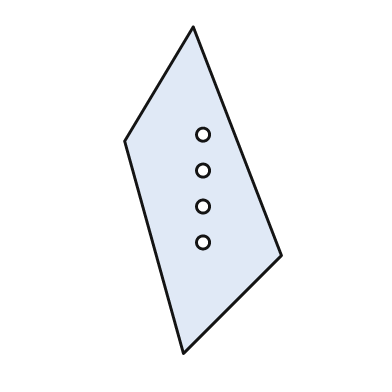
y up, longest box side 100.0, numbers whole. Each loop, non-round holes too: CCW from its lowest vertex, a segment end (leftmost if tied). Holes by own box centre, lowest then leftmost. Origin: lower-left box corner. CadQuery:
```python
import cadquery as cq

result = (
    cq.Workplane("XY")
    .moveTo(18.0, 0.0)
    .lineTo(48.0, 30.0)
    .lineTo(21.0, 100.0)
    .lineTo(0.0, 65.0)
    .close()
    .moveTo(24.0, 34.0)
    .circle(2.0)
    .moveTo(24.0, 45.0)
    .circle(2.0)
    .moveTo(24.0, 56.0)
    .circle(2.0)
    .moveTo(24.0, 67.0)
    .circle(2.0)
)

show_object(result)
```